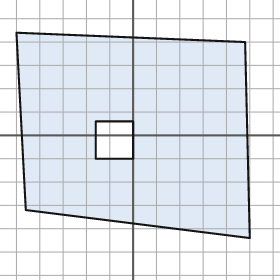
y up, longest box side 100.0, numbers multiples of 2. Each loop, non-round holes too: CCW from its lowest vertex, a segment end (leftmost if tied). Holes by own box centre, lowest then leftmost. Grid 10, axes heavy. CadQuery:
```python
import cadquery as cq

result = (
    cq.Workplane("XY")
    .moveTo(50.0, -44.0)
    .lineTo(48.0, 40.0)
    .lineTo(-50.0, 44.0)
    .lineTo(-46.0, -32.0)
    .close()
    .moveTo(-16.0, -10.0)
    .lineTo(0.0, -10.0)
    .lineTo(0.0, 6.0)
    .lineTo(-16.0, 6.0)
    .close()
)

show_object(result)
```